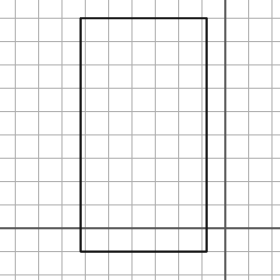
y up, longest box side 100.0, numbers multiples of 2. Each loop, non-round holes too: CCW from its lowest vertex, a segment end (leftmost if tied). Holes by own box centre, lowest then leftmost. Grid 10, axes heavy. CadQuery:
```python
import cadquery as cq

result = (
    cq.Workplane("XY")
    .moveTo(-62.0, -10.0)
    .lineTo(-8.0, -10.0)
    .lineTo(-8.0, 90.0)
    .lineTo(-62.0, 90.0)
    .close()
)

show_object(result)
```